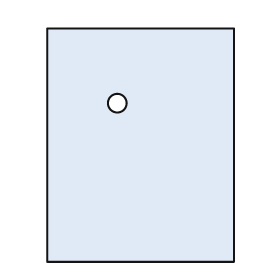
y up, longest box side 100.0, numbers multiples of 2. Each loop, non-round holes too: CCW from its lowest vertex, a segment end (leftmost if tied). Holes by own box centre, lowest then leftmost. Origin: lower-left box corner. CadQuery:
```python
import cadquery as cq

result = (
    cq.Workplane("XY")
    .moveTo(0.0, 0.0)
    .lineTo(80.0, 0.0)
    .lineTo(80.0, 100.0)
    .lineTo(0.0, 100.0)
    .close()
    .moveTo(30.0, 68.0)
    .circle(4.0)
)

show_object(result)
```